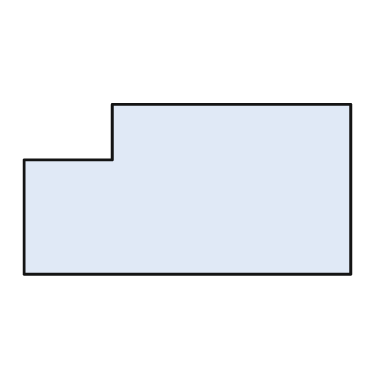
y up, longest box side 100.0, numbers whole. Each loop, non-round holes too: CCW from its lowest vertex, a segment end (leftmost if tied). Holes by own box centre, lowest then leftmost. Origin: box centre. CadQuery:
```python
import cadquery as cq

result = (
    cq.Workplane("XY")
    .moveTo(-50.0, -26.0)
    .lineTo(50.0, -26.0)
    .lineTo(50.0, 26.0)
    .lineTo(-23.0, 26.0)
    .lineTo(-23.0, 9.0)
    .lineTo(-50.0, 9.0)
    .close()
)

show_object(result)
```